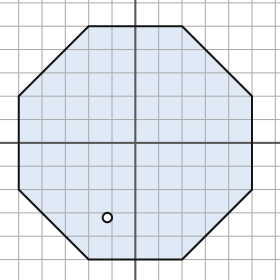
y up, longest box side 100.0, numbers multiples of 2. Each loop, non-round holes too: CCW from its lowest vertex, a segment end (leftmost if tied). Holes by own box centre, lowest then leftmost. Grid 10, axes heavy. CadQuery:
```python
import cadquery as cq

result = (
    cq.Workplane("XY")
    .moveTo(-20.0, -50.0)
    .lineTo(20.0, -50.0)
    .lineTo(50.0, -20.0)
    .lineTo(50.0, 20.0)
    .lineTo(20.0, 50.0)
    .lineTo(-20.0, 50.0)
    .lineTo(-50.0, 20.0)
    .lineTo(-50.0, -20.0)
    .close()
    .moveTo(-12.0, -32.0)
    .circle(2.0)
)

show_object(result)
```